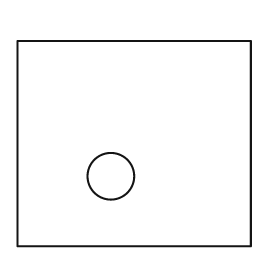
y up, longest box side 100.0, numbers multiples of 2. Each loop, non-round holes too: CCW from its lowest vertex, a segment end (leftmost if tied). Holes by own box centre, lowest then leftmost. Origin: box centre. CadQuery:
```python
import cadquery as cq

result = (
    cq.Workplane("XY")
    .moveTo(-50.0, -44.0)
    .lineTo(50.0, -44.0)
    .lineTo(50.0, 44.0)
    .lineTo(-50.0, 44.0)
    .close()
    .moveTo(-10.0, -14.0)
    .circle(10.0)
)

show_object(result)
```